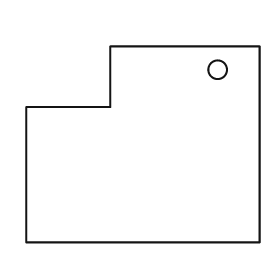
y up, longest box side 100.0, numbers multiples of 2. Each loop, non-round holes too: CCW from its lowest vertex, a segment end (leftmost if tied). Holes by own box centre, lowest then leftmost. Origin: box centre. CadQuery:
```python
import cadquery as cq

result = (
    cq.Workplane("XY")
    .moveTo(-50.0, -42.0)
    .lineTo(50.0, -42.0)
    .lineTo(50.0, 42.0)
    .lineTo(-14.0, 42.0)
    .lineTo(-14.0, 16.0)
    .lineTo(-50.0, 16.0)
    .close()
    .moveTo(32.0, 32.0)
    .circle(4.0)
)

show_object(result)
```